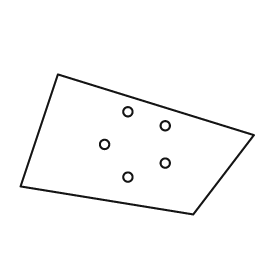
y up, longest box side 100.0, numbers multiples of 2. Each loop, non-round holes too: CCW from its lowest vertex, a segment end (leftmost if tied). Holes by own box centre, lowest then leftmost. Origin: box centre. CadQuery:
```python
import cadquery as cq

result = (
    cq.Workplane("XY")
    .moveTo(24.0, -30.0)
    .lineTo(50.0, 4.0)
    .lineTo(-34.0, 30.0)
    .lineTo(-50.0, -18.0)
    .close()
    .moveTo(-4.0, -14.0)
    .circle(2.0)
    .moveTo(12.0, -8.0)
    .circle(2.0)
    .moveTo(-14.0, 0.0)
    .circle(2.0)
    .moveTo(12.0, 8.0)
    .circle(2.0)
    .moveTo(-4.0, 14.0)
    .circle(2.0)
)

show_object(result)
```